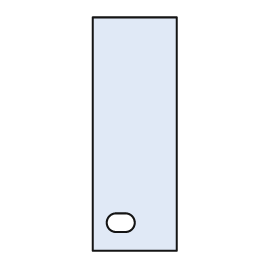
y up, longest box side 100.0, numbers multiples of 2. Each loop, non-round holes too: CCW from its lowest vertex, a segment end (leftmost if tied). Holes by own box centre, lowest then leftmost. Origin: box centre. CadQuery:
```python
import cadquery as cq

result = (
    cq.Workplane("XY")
    .moveTo(-18.0, -50.0)
    .lineTo(18.0, -50.0)
    .lineTo(18.0, 50.0)
    .lineTo(-18.0, 50.0)
    .close()
    .moveTo(-8.0, -42.0)
    .lineTo(-4.0, -42.0)
    .threePointArc((0.0, -38.0), (-4.0, -34.0))
    .lineTo(-8.0, -34.0)
    .threePointArc((-12.0, -38.0), (-8.0, -42.0))
    .close()
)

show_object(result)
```